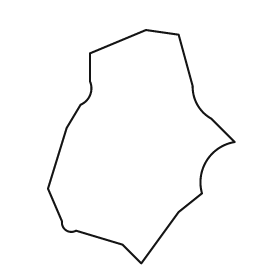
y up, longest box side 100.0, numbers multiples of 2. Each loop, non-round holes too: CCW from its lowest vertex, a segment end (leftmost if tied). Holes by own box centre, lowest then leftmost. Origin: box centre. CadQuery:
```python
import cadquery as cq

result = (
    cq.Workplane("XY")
    .moveTo(0.0, -50.0)
    .lineTo(16.0, -28.0)
    .lineTo(26.0, -20.0)
    .threePointArc((28.0, -6.0), (40.0, 2.0))
    .lineTo(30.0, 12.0)
    .threePointArc((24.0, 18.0), (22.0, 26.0))
    .lineTo(16.0, 48.0)
    .lineTo(2.0, 50.0)
    .lineTo(-22.0, 40.0)
    .lineTo(-22.0, 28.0)
    .threePointArc((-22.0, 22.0), (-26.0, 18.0))
    .lineTo(-32.0, 8.0)
    .lineTo(-40.0, -18.0)
    .lineTo(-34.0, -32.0)
    .threePointArc((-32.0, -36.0), (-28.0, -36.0))
    .lineTo(-8.0, -42.0)
    .close()
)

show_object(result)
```